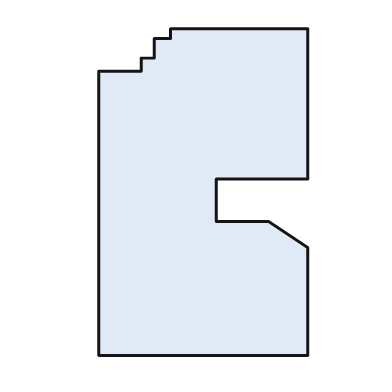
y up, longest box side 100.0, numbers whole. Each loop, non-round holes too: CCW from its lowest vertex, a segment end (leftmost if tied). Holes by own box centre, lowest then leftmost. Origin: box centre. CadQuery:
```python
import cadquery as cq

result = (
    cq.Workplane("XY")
    .moveTo(-32.0, -50.0)
    .lineTo(32.0, -50.0)
    .lineTo(32.0, -17.0)
    .lineTo(20.0, -9.0)
    .lineTo(4.0, -9.0)
    .lineTo(4.0, 4.0)
    .lineTo(32.0, 4.0)
    .lineTo(32.0, 50.0)
    .lineTo(-10.0, 50.0)
    .lineTo(-10.0, 47.0)
    .lineTo(-15.0, 47.0)
    .lineTo(-15.0, 41.0)
    .lineTo(-19.0, 41.0)
    .lineTo(-19.0, 37.0)
    .lineTo(-32.0, 37.0)
    .close()
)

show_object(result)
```